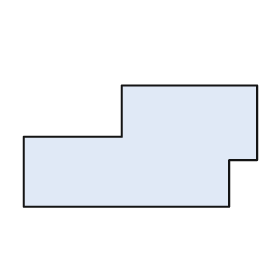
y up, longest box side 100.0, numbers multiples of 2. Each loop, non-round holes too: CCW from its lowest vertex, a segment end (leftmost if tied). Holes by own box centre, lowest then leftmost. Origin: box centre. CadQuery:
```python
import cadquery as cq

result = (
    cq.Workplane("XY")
    .moveTo(-50.0, -26.0)
    .lineTo(38.0, -26.0)
    .lineTo(38.0, -6.0)
    .lineTo(50.0, -6.0)
    .lineTo(50.0, 26.0)
    .lineTo(-8.0, 26.0)
    .lineTo(-8.0, 4.0)
    .lineTo(-50.0, 4.0)
    .close()
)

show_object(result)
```